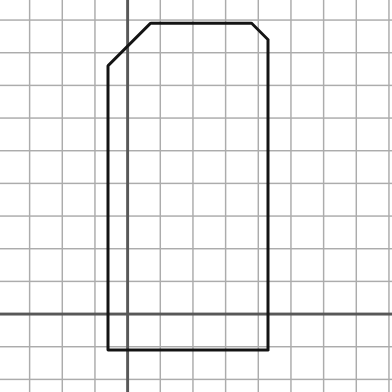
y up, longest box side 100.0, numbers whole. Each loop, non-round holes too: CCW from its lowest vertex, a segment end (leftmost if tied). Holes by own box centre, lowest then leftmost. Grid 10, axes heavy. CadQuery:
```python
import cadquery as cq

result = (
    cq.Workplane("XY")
    .moveTo(-6.0, -11.0)
    .lineTo(43.0, -11.0)
    .lineTo(43.0, 84.0)
    .lineTo(38.0, 89.0)
    .lineTo(7.0, 89.0)
    .lineTo(-6.0, 76.0)
    .close()
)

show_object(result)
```